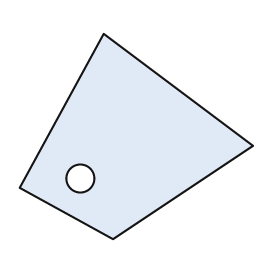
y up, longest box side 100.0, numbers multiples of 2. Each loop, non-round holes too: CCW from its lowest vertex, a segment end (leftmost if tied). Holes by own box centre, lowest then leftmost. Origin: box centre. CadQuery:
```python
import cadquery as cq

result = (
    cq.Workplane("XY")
    .moveTo(-10.0, -44.0)
    .lineTo(50.0, -4.0)
    .lineTo(-14.0, 44.0)
    .lineTo(-50.0, -22.0)
    .close()
    .moveTo(-24.0, -18.0)
    .circle(6.0)
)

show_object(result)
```